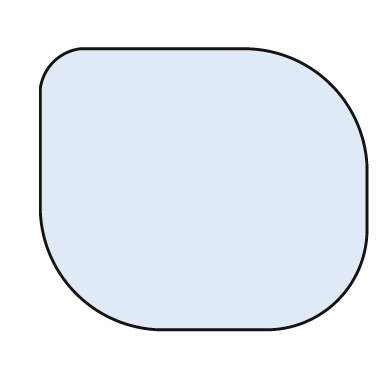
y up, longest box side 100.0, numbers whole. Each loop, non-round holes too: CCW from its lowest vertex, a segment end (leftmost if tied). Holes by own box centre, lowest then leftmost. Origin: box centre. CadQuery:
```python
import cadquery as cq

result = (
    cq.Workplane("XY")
    .moveTo(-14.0, -43.0)
    .lineTo(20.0, -43.0)
    .threePointArc((41.0, -34.0), (50.0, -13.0))
    .lineTo(50.0, 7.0)
    .threePointArc((39.0, 32.0), (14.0, 43.0))
    .lineTo(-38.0, 43.0)
    .threePointArc((-46.0, 39.0), (-50.0, 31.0))
    .lineTo(-50.0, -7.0)
    .threePointArc((-39.0, -32.0), (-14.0, -43.0))
    .close()
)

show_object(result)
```